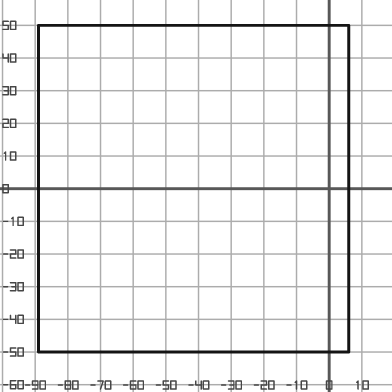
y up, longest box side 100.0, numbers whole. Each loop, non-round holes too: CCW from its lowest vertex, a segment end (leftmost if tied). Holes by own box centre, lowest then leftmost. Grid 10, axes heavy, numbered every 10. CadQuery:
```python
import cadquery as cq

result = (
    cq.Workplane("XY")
    .moveTo(-89.0, -50.0)
    .lineTo(6.0, -50.0)
    .lineTo(6.0, 50.0)
    .lineTo(-89.0, 50.0)
    .close()
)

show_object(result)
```